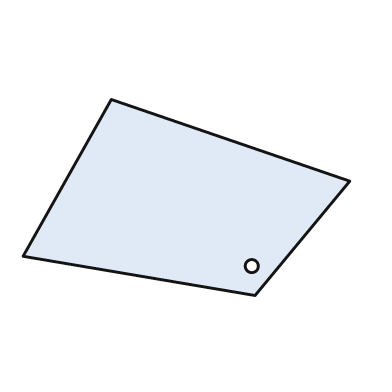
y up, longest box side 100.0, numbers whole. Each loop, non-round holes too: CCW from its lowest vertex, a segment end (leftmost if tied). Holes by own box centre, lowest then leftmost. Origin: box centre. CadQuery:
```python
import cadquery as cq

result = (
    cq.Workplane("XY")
    .moveTo(21.0, -30.0)
    .lineTo(50.0, 5.0)
    .lineTo(-23.0, 30.0)
    .lineTo(-50.0, -18.0)
    .close()
    .moveTo(20.0, -21.0)
    .circle(2.0)
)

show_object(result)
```